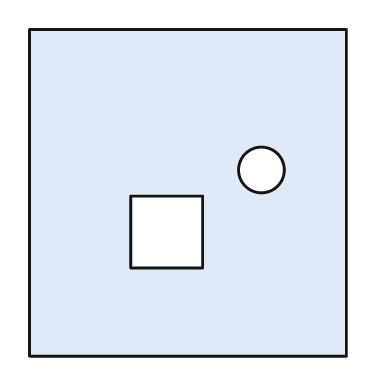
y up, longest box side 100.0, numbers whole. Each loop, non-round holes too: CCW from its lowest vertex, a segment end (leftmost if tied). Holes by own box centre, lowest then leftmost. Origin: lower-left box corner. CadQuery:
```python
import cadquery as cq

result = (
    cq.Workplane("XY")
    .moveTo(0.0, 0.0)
    .lineTo(97.0, 0.0)
    .lineTo(97.0, 100.0)
    .lineTo(0.0, 100.0)
    .close()
    .moveTo(31.0, 27.0)
    .lineTo(53.0, 27.0)
    .lineTo(53.0, 49.0)
    .lineTo(31.0, 49.0)
    .close()
    .moveTo(71.0, 57.0)
    .circle(7.0)
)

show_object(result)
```